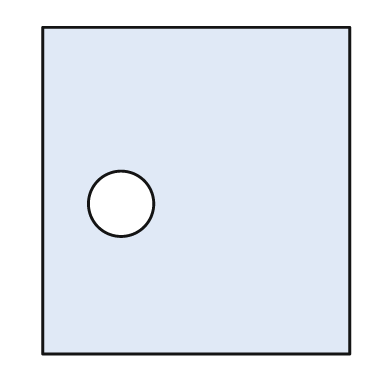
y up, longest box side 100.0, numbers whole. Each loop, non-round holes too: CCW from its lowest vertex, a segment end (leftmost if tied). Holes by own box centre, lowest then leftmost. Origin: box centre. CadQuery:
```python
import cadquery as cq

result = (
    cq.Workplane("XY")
    .moveTo(-47.0, -50.0)
    .lineTo(47.0, -50.0)
    .lineTo(47.0, 50.0)
    .lineTo(-47.0, 50.0)
    .close()
    .moveTo(-23.0, -4.0)
    .circle(10.0)
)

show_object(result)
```